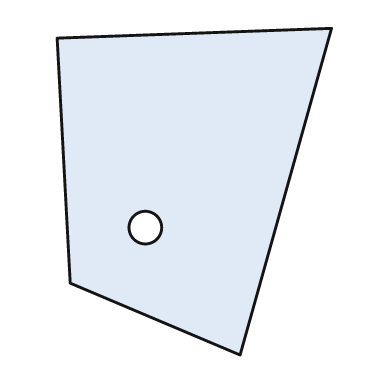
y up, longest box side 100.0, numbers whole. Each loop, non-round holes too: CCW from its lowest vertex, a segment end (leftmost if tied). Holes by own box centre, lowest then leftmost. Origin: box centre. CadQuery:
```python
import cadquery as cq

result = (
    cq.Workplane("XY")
    .moveTo(14.0, -50.0)
    .lineTo(42.0, 50.0)
    .lineTo(-42.0, 47.0)
    .lineTo(-38.0, -28.0)
    .close()
    .moveTo(-15.0, -11.0)
    .circle(5.0)
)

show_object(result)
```